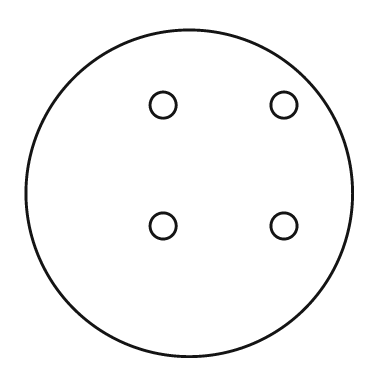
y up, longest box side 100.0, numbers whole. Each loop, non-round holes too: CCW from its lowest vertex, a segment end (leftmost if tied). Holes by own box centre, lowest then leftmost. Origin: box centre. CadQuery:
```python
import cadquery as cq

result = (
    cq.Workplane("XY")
    .moveTo(0.0, 0.0)
    .circle(50.0)
    .moveTo(-8.0, -10.0)
    .circle(4.0)
    .moveTo(29.0, -10.0)
    .circle(4.0)
    .moveTo(-8.0, 27.0)
    .circle(4.0)
    .moveTo(29.0, 27.0)
    .circle(4.0)
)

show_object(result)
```